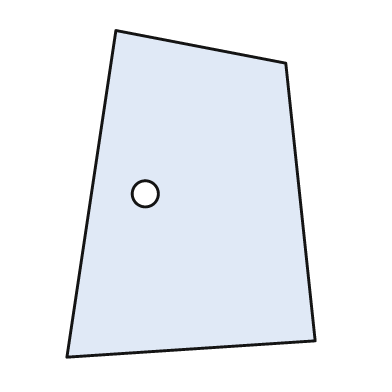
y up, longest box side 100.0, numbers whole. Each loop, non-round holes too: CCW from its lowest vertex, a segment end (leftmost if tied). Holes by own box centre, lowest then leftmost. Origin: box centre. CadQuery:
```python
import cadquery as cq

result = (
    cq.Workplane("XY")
    .moveTo(-38.0, -50.0)
    .lineTo(38.0, -45.0)
    .lineTo(29.0, 40.0)
    .lineTo(-23.0, 50.0)
    .close()
    .moveTo(-14.0, 0.0)
    .circle(4.0)
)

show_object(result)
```